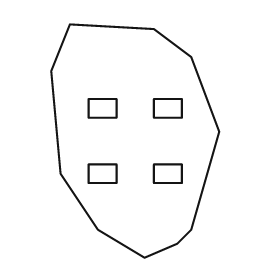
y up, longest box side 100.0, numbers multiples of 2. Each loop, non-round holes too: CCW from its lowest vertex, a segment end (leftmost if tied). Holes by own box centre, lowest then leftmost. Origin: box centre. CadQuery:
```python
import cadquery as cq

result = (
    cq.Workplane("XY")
    .moveTo(4.0, -50.0)
    .lineTo(18.0, -44.0)
    .lineTo(24.0, -38.0)
    .lineTo(36.0, 4.0)
    .lineTo(24.0, 36.0)
    .lineTo(8.0, 48.0)
    .lineTo(-28.0, 50.0)
    .lineTo(-36.0, 30.0)
    .lineTo(-32.0, -14.0)
    .lineTo(-16.0, -38.0)
    .close()
    .moveTo(-20.0, -18.0)
    .lineTo(-8.0, -18.0)
    .lineTo(-8.0, -10.0)
    .lineTo(-20.0, -10.0)
    .close()
    .moveTo(8.0, -18.0)
    .lineTo(20.0, -18.0)
    .lineTo(20.0, -10.0)
    .lineTo(8.0, -10.0)
    .close()
    .moveTo(-20.0, 10.0)
    .lineTo(-8.0, 10.0)
    .lineTo(-8.0, 18.0)
    .lineTo(-20.0, 18.0)
    .close()
    .moveTo(8.0, 10.0)
    .lineTo(20.0, 10.0)
    .lineTo(20.0, 18.0)
    .lineTo(8.0, 18.0)
    .close()
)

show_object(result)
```